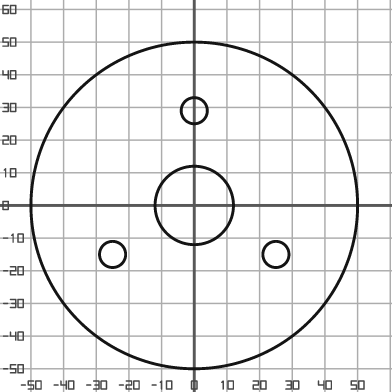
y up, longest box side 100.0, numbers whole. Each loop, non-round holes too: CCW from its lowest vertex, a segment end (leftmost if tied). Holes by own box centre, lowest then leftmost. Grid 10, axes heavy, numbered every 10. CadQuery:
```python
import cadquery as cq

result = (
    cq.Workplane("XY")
    .moveTo(0.0, 0.0)
    .circle(50.0)
    .moveTo(-25.0, -15.0)
    .circle(4.0)
    .moveTo(25.0, -15.0)
    .circle(4.0)
    .moveTo(0.0, 0.0)
    .circle(12.0)
    .moveTo(0.0, 29.0)
    .circle(4.0)
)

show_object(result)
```